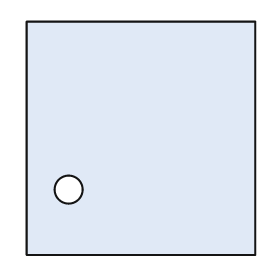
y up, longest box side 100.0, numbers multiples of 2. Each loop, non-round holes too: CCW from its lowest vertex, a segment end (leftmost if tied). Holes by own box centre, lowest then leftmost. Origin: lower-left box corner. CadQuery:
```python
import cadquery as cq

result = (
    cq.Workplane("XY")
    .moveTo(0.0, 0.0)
    .lineTo(98.0, 0.0)
    .lineTo(98.0, 100.0)
    .lineTo(0.0, 100.0)
    .close()
    .moveTo(18.0, 28.0)
    .circle(6.0)
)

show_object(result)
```